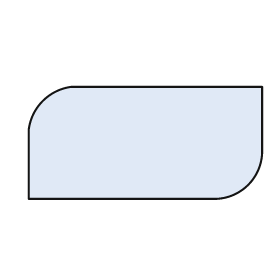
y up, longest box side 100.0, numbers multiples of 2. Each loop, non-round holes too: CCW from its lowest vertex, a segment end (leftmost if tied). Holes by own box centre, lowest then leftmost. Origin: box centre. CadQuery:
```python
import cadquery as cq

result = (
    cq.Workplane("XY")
    .moveTo(-50.0, -24.0)
    .lineTo(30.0, -24.0)
    .threePointArc((44.0, -18.0), (50.0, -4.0))
    .lineTo(50.0, 24.0)
    .lineTo(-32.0, 24.0)
    .threePointArc((-44.0, 18.0), (-50.0, 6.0))
    .close()
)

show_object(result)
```